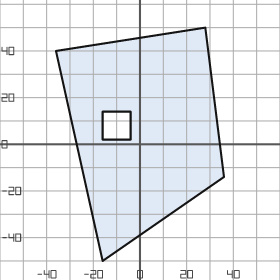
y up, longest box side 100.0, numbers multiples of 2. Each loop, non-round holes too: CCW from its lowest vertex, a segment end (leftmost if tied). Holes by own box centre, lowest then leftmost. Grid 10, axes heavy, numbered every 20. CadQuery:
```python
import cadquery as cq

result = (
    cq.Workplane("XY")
    .moveTo(-16.0, -50.0)
    .lineTo(36.0, -14.0)
    .lineTo(28.0, 50.0)
    .lineTo(-36.0, 40.0)
    .close()
    .moveTo(-16.0, 2.0)
    .lineTo(-4.0, 2.0)
    .lineTo(-4.0, 14.0)
    .lineTo(-16.0, 14.0)
    .close()
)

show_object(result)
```